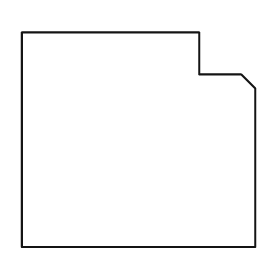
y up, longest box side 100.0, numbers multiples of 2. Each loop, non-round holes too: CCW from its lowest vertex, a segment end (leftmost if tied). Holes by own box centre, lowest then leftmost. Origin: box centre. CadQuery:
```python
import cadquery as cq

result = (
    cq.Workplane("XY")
    .moveTo(-50.0, -46.0)
    .lineTo(50.0, -46.0)
    .lineTo(50.0, 22.0)
    .lineTo(44.0, 28.0)
    .lineTo(26.0, 28.0)
    .lineTo(26.0, 46.0)
    .lineTo(-50.0, 46.0)
    .close()
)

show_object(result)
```